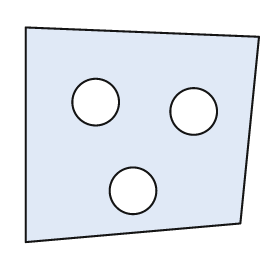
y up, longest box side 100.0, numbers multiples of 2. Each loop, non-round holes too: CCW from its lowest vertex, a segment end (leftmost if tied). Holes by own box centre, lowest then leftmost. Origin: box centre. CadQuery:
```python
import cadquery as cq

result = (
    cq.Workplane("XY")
    .moveTo(-50.0, -46.0)
    .lineTo(42.0, -38.0)
    .lineTo(50.0, 42.0)
    .lineTo(-50.0, 46.0)
    .close()
    .moveTo(-4.0, -24.0)
    .circle(10.0)
    .moveTo(22.0, 10.0)
    .circle(10.0)
    .moveTo(-20.0, 14.0)
    .circle(10.0)
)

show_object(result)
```